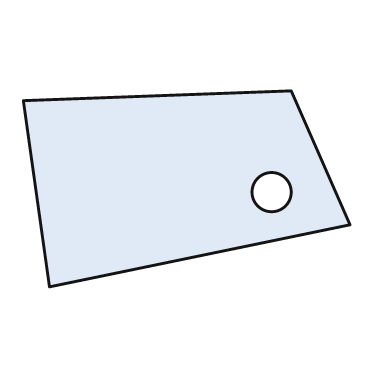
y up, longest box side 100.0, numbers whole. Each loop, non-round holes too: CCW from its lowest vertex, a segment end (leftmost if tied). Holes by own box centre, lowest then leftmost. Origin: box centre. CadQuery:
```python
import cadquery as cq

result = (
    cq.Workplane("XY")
    .moveTo(-42.0, -30.0)
    .lineTo(50.0, -11.0)
    .lineTo(32.0, 30.0)
    .lineTo(-50.0, 27.0)
    .close()
    .moveTo(26.0, -1.0)
    .circle(6.0)
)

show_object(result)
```